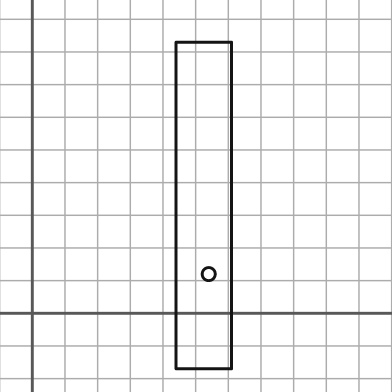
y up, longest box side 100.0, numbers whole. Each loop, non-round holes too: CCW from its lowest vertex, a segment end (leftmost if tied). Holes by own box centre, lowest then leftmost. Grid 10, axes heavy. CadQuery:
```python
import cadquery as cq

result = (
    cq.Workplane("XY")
    .moveTo(44.0, -17.0)
    .lineTo(61.0, -17.0)
    .lineTo(61.0, 83.0)
    .lineTo(44.0, 83.0)
    .close()
    .moveTo(54.0, 12.0)
    .circle(2.0)
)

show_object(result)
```